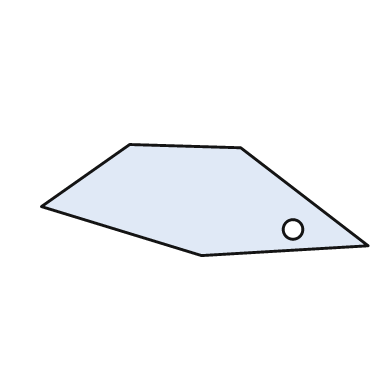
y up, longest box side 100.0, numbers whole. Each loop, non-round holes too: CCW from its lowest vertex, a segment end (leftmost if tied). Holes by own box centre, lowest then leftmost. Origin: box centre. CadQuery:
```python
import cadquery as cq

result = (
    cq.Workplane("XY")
    .moveTo(-1.0, -17.0)
    .lineTo(50.0, -14.0)
    .lineTo(11.0, 16.0)
    .lineTo(-23.0, 17.0)
    .lineTo(-50.0, -2.0)
    .close()
    .moveTo(27.0, -9.0)
    .circle(3.0)
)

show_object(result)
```